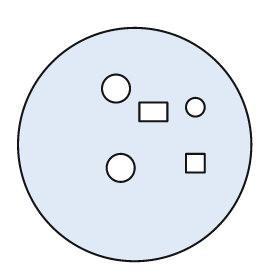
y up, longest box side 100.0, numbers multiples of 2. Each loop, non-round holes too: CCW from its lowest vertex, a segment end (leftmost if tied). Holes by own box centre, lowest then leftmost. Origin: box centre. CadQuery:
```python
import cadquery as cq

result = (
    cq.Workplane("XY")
    .moveTo(0.0, 0.0)
    .circle(50.0)
    .moveTo(-6.0, -10.0)
    .circle(6.0)
    .moveTo(22.0, -12.0)
    .lineTo(30.0, -12.0)
    .lineTo(30.0, -4.0)
    .lineTo(22.0, -4.0)
    .close()
    .moveTo(2.0, 10.0)
    .lineTo(14.0, 10.0)
    .lineTo(14.0, 18.0)
    .lineTo(2.0, 18.0)
    .close()
    .moveTo(26.0, 16.0)
    .circle(4.0)
    .moveTo(-8.0, 24.0)
    .circle(6.0)
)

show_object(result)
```